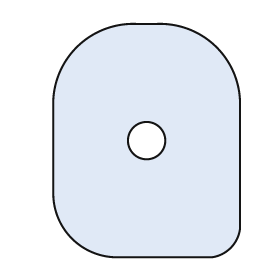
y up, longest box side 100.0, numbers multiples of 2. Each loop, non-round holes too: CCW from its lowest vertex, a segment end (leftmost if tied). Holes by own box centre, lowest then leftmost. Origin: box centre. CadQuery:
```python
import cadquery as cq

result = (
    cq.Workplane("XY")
    .moveTo(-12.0, -50.0)
    .lineTo(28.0, -50.0)
    .threePointArc((36.0, -46.0), (40.0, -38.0))
    .lineTo(40.0, 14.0)
    .threePointArc((30.0, 40.0), (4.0, 50.0))
    .lineTo(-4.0, 50.0)
    .threePointArc((-30.0, 40.0), (-40.0, 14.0))
    .lineTo(-40.0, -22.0)
    .threePointArc((-32.0, -42.0), (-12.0, -50.0))
    .close()
    .moveTo(0.0, 0.0)
    .circle(8.0)
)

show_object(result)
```